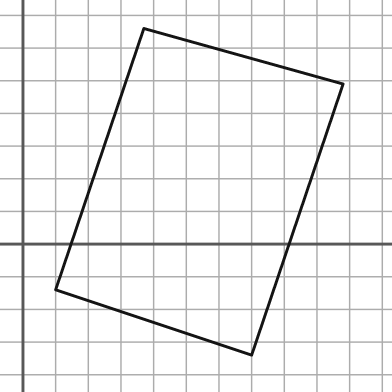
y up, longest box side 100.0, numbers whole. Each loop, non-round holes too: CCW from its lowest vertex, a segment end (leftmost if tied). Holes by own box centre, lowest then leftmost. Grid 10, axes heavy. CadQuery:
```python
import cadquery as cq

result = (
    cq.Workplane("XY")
    .moveTo(70.0, -34.0)
    .lineTo(98.0, 49.0)
    .lineTo(37.0, 66.0)
    .lineTo(10.0, -14.0)
    .close()
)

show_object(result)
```